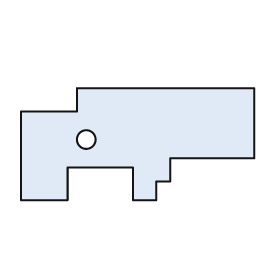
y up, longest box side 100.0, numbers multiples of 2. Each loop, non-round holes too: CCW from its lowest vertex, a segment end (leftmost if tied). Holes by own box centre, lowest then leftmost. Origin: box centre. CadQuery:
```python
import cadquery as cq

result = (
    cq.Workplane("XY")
    .moveTo(-50.0, -24.0)
    .lineTo(-30.0, -24.0)
    .lineTo(-30.0, -10.0)
    .lineTo(-2.0, -10.0)
    .lineTo(-2.0, -24.0)
    .lineTo(8.0, -24.0)
    .lineTo(8.0, -16.0)
    .lineTo(14.0, -16.0)
    .lineTo(14.0, -6.0)
    .lineTo(50.0, -6.0)
    .lineTo(50.0, 24.0)
    .lineTo(-26.0, 24.0)
    .lineTo(-26.0, 14.0)
    .lineTo(-50.0, 14.0)
    .close()
    .moveTo(-22.0, 2.0)
    .circle(4.0)
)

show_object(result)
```